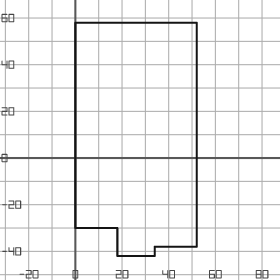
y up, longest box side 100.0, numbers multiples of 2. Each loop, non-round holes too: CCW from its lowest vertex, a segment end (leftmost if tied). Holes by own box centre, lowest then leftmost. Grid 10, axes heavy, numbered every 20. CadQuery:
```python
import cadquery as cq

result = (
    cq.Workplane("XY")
    .moveTo(18.0, -42.0)
    .lineTo(34.0, -42.0)
    .lineTo(34.0, -38.0)
    .lineTo(52.0, -38.0)
    .lineTo(52.0, 58.0)
    .lineTo(0.0, 58.0)
    .lineTo(0.0, -30.0)
    .lineTo(18.0, -30.0)
    .close()
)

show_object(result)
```